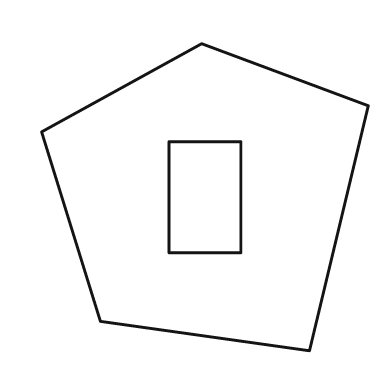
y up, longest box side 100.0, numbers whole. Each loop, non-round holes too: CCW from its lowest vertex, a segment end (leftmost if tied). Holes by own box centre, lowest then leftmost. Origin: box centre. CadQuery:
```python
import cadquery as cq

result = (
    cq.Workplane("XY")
    .moveTo(32.0, -47.0)
    .lineTo(50.0, 28.0)
    .lineTo(-1.0, 47.0)
    .lineTo(-50.0, 20.0)
    .lineTo(-32.0, -38.0)
    .close()
    .moveTo(-11.0, -17.0)
    .lineTo(11.0, -17.0)
    .lineTo(11.0, 17.0)
    .lineTo(-11.0, 17.0)
    .close()
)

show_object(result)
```